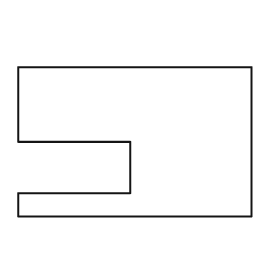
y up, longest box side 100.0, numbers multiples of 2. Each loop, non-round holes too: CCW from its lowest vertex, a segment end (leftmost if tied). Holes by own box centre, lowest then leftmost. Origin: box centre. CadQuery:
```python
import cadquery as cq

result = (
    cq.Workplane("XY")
    .moveTo(-50.0, -32.0)
    .lineTo(50.0, -32.0)
    .lineTo(50.0, 32.0)
    .lineTo(-50.0, 32.0)
    .lineTo(-50.0, 0.0)
    .lineTo(-2.0, 0.0)
    .lineTo(-2.0, -22.0)
    .lineTo(-50.0, -22.0)
    .close()
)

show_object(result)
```